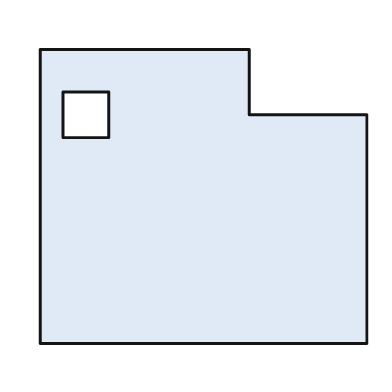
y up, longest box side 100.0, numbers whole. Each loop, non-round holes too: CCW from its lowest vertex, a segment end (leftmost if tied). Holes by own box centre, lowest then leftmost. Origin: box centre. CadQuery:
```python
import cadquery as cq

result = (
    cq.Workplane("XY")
    .moveTo(-50.0, -45.0)
    .lineTo(50.0, -45.0)
    .lineTo(50.0, 25.0)
    .lineTo(14.0, 25.0)
    .lineTo(14.0, 45.0)
    .lineTo(-50.0, 45.0)
    .close()
    .moveTo(-43.0, 18.0)
    .lineTo(-29.0, 18.0)
    .lineTo(-29.0, 32.0)
    .lineTo(-43.0, 32.0)
    .close()
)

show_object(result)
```